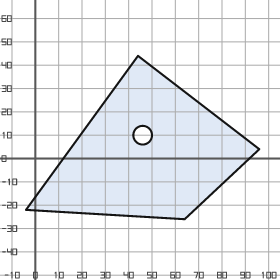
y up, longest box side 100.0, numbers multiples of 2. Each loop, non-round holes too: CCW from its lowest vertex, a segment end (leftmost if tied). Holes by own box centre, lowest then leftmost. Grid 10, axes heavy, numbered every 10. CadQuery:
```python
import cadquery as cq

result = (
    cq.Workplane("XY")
    .moveTo(64.0, -26.0)
    .lineTo(96.0, 4.0)
    .lineTo(44.0, 44.0)
    .lineTo(-4.0, -22.0)
    .close()
    .moveTo(46.0, 10.0)
    .circle(4.0)
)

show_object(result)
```